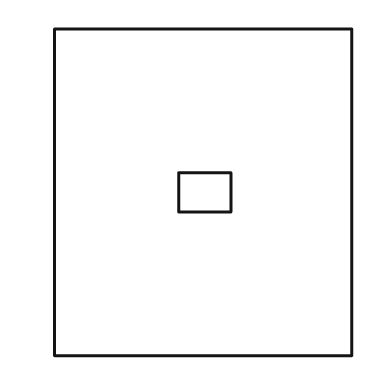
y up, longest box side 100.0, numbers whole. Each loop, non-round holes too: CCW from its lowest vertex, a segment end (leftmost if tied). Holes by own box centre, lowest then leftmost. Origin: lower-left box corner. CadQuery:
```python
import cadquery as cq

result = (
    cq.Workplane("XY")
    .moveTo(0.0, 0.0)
    .lineTo(91.0, 0.0)
    .lineTo(91.0, 100.0)
    .lineTo(0.0, 100.0)
    .close()
    .moveTo(38.0, 44.0)
    .lineTo(54.0, 44.0)
    .lineTo(54.0, 56.0)
    .lineTo(38.0, 56.0)
    .close()
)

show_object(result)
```